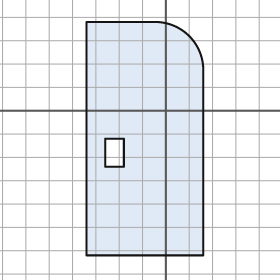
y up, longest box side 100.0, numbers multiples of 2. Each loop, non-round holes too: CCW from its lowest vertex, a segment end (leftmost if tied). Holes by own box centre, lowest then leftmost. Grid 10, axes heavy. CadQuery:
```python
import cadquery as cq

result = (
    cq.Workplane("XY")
    .moveTo(-34.0, -62.0)
    .lineTo(16.0, -62.0)
    .lineTo(16.0, 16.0)
    .threePointArc((10.0, 32.0), (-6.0, 38.0))
    .lineTo(-34.0, 38.0)
    .close()
    .moveTo(-26.0, -24.0)
    .lineTo(-18.0, -24.0)
    .lineTo(-18.0, -12.0)
    .lineTo(-26.0, -12.0)
    .close()
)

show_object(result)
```